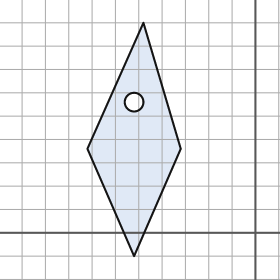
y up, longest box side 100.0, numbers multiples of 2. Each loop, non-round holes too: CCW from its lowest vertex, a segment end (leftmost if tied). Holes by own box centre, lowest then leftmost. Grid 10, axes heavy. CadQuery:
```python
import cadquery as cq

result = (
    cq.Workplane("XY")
    .moveTo(-52.0, -10.0)
    .lineTo(-32.0, 36.0)
    .lineTo(-48.0, 90.0)
    .lineTo(-72.0, 36.0)
    .close()
    .moveTo(-52.0, 56.0)
    .circle(4.0)
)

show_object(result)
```